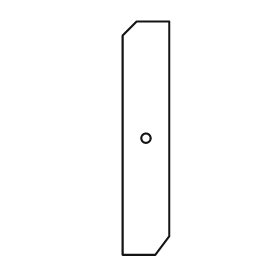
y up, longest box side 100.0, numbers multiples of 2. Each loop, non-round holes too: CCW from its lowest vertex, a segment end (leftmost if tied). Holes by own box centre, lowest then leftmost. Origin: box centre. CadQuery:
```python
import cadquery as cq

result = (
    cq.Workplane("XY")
    .moveTo(-10.0, -50.0)
    .lineTo(4.0, -50.0)
    .lineTo(10.0, -42.0)
    .lineTo(10.0, 50.0)
    .lineTo(-4.0, 50.0)
    .lineTo(-10.0, 44.0)
    .close()
    .moveTo(0.0, 0.0)
    .circle(2.0)
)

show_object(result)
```